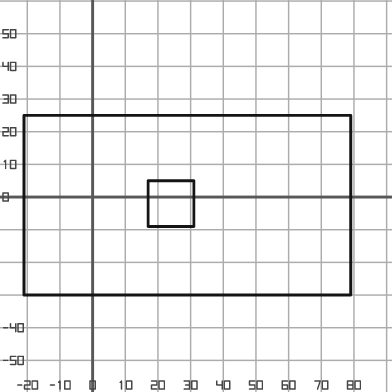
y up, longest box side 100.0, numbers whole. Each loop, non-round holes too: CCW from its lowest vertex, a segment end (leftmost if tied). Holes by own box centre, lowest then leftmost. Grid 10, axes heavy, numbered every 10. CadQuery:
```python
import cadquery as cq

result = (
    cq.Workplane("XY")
    .moveTo(-21.0, -30.0)
    .lineTo(79.0, -30.0)
    .lineTo(79.0, 25.0)
    .lineTo(-21.0, 25.0)
    .close()
    .moveTo(17.0, -9.0)
    .lineTo(31.0, -9.0)
    .lineTo(31.0, 5.0)
    .lineTo(17.0, 5.0)
    .close()
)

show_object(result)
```